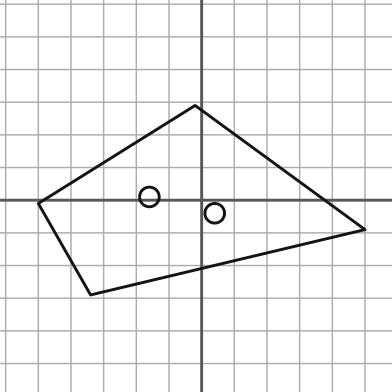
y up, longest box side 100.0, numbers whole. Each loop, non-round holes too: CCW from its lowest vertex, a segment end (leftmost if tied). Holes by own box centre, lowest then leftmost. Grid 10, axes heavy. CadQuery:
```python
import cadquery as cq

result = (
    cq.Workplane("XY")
    .moveTo(-34.0, -29.0)
    .lineTo(50.0, -9.0)
    .lineTo(-2.0, 29.0)
    .lineTo(-50.0, -1.0)
    .close()
    .moveTo(4.0, -4.0)
    .circle(3.0)
    .moveTo(-16.0, 1.0)
    .circle(3.0)
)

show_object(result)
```